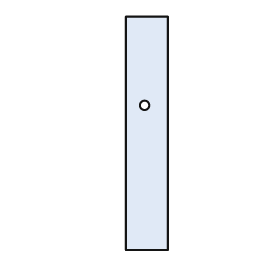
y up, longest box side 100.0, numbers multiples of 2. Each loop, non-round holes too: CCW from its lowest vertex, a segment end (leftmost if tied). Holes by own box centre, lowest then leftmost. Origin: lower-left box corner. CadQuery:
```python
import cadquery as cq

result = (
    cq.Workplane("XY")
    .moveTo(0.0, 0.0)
    .lineTo(18.0, 0.0)
    .lineTo(18.0, 100.0)
    .lineTo(0.0, 100.0)
    .close()
    .moveTo(8.0, 62.0)
    .circle(2.0)
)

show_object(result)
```